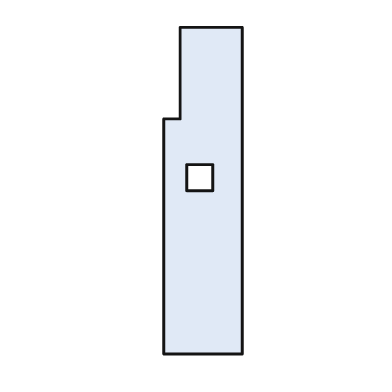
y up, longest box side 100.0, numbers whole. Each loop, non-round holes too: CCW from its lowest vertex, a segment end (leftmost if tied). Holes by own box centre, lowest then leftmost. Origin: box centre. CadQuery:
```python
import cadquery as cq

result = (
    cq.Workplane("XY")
    .moveTo(-12.0, -50.0)
    .lineTo(12.0, -50.0)
    .lineTo(12.0, 50.0)
    .lineTo(-7.0, 50.0)
    .lineTo(-7.0, 22.0)
    .lineTo(-12.0, 22.0)
    .close()
    .moveTo(-5.0, 0.0)
    .lineTo(3.0, 0.0)
    .lineTo(3.0, 8.0)
    .lineTo(-5.0, 8.0)
    .close()
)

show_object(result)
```